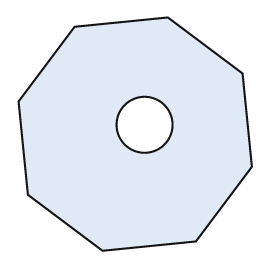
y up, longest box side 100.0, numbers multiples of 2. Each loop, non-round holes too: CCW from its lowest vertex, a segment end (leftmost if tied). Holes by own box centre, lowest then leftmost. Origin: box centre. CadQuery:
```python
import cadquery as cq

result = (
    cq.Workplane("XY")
    .moveTo(-14.0, -50.0)
    .lineTo(26.0, -46.0)
    .lineTo(50.0, -14.0)
    .lineTo(46.0, 26.0)
    .lineTo(14.0, 50.0)
    .lineTo(-26.0, 46.0)
    .lineTo(-50.0, 14.0)
    .lineTo(-46.0, -26.0)
    .close()
    .moveTo(4.0, 4.0)
    .circle(12.0)
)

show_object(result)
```